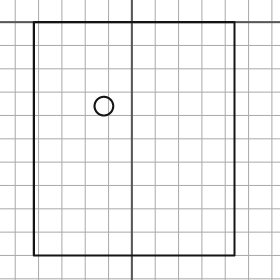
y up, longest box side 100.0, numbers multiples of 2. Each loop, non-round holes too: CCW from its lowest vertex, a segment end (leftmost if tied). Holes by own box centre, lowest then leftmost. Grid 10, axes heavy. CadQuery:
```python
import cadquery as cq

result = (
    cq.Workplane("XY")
    .moveTo(-42.0, -100.0)
    .lineTo(44.0, -100.0)
    .lineTo(44.0, 0.0)
    .lineTo(-42.0, 0.0)
    .close()
    .moveTo(-12.0, -36.0)
    .circle(4.0)
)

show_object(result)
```